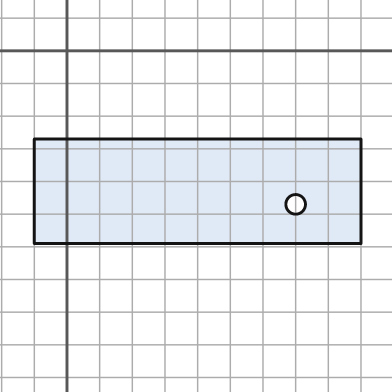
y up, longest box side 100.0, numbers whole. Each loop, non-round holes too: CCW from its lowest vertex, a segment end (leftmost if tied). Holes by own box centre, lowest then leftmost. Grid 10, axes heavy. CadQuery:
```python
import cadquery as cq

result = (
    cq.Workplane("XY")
    .moveTo(-10.0, -59.0)
    .lineTo(90.0, -59.0)
    .lineTo(90.0, -27.0)
    .lineTo(-10.0, -27.0)
    .close()
    .moveTo(70.0, -47.0)
    .circle(3.0)
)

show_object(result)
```